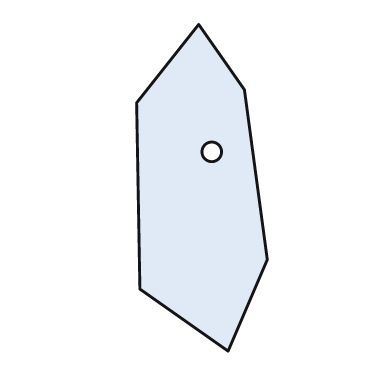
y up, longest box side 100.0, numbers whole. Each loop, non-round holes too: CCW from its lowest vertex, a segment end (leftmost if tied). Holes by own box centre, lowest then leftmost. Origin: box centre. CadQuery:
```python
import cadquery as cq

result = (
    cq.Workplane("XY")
    .moveTo(8.0, -50.0)
    .lineTo(20.0, -22.0)
    .lineTo(13.0, 30.0)
    .lineTo(-1.0, 50.0)
    .lineTo(-20.0, 26.0)
    .lineTo(-19.0, -31.0)
    .close()
    .moveTo(3.0, 11.0)
    .circle(3.0)
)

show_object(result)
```